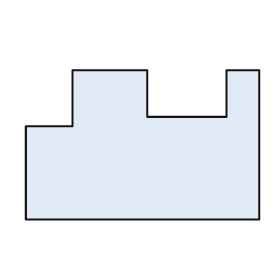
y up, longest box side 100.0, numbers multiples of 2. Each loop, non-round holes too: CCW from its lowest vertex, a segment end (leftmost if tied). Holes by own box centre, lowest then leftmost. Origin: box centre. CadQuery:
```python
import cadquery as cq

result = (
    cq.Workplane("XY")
    .moveTo(-50.0, -32.0)
    .lineTo(50.0, -32.0)
    .lineTo(50.0, 32.0)
    .lineTo(36.0, 32.0)
    .lineTo(36.0, 12.0)
    .lineTo(2.0, 12.0)
    .lineTo(2.0, 32.0)
    .lineTo(-30.0, 32.0)
    .lineTo(-30.0, 8.0)
    .lineTo(-50.0, 8.0)
    .close()
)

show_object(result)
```